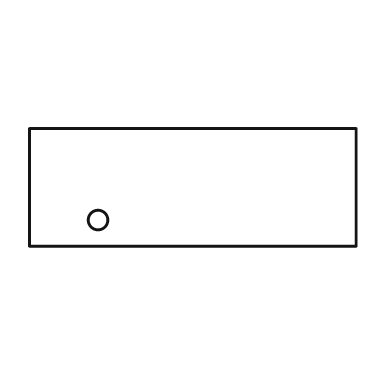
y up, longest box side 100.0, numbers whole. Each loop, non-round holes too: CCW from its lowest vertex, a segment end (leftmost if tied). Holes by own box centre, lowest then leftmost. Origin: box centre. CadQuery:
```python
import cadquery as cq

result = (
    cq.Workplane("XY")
    .moveTo(-50.0, -18.0)
    .lineTo(50.0, -18.0)
    .lineTo(50.0, 18.0)
    .lineTo(-50.0, 18.0)
    .close()
    .moveTo(-29.0, -10.0)
    .circle(3.0)
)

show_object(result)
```